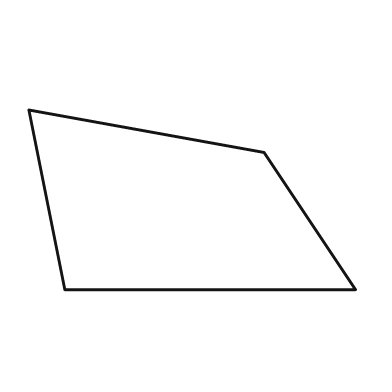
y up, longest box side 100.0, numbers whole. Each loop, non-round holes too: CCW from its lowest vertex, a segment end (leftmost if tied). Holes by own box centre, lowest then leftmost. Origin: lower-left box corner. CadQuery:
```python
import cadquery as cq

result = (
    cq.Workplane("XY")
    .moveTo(11.0, 0.0)
    .lineTo(100.0, 0.0)
    .lineTo(72.0, 42.0)
    .lineTo(0.0, 55.0)
    .close()
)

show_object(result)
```